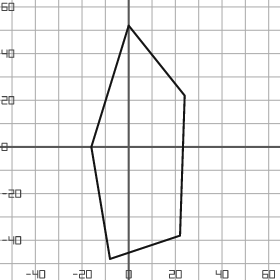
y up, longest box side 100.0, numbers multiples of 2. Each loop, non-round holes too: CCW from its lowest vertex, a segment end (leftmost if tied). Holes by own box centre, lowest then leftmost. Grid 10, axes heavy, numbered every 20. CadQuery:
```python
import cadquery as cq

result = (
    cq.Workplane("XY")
    .moveTo(-8.0, -48.0)
    .lineTo(22.0, -38.0)
    .lineTo(24.0, 22.0)
    .lineTo(0.0, 52.0)
    .lineTo(-16.0, 0.0)
    .close()
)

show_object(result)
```